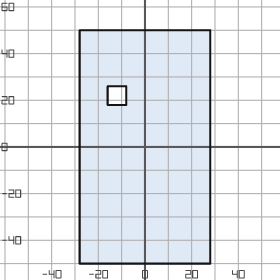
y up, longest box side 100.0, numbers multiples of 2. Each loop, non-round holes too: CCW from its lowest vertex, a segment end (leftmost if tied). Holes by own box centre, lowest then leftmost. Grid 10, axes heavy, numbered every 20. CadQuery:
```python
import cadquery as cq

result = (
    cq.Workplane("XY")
    .moveTo(-28.0, -50.0)
    .lineTo(28.0, -50.0)
    .lineTo(28.0, 50.0)
    .lineTo(-28.0, 50.0)
    .close()
    .moveTo(-16.0, 18.0)
    .lineTo(-8.0, 18.0)
    .lineTo(-8.0, 26.0)
    .lineTo(-16.0, 26.0)
    .close()
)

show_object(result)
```